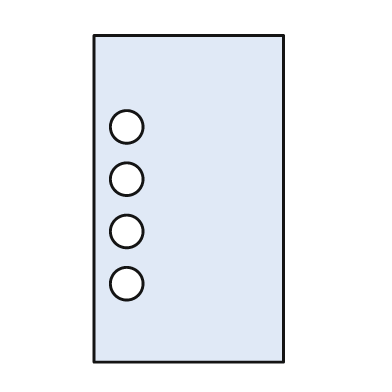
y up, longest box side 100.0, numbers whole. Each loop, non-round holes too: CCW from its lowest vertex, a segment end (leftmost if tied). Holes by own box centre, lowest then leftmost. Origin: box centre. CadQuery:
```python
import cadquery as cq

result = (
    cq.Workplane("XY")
    .moveTo(-29.0, -50.0)
    .lineTo(29.0, -50.0)
    .lineTo(29.0, 50.0)
    .lineTo(-29.0, 50.0)
    .close()
    .moveTo(-19.0, -26.0)
    .circle(5.0)
    .moveTo(-19.0, -10.0)
    .circle(5.0)
    .moveTo(-19.0, 6.0)
    .circle(5.0)
    .moveTo(-19.0, 22.0)
    .circle(5.0)
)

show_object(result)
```